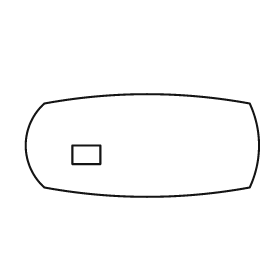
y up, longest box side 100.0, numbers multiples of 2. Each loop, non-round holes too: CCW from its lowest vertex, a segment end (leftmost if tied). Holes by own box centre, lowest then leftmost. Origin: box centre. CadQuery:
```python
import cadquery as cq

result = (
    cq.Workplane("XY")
    .moveTo(-42.0, -18.0)
    .threePointArc((2.0, -22.0), (46.0, -18.0))
    .threePointArc((50.0, 0.0), (46.0, 18.0))
    .threePointArc((2.0, 22.0), (-42.0, 18.0))
    .threePointArc((-50.0, 0.0), (-42.0, -18.0))
    .close()
    .moveTo(-30.0, -8.0)
    .lineTo(-18.0, -8.0)
    .lineTo(-18.0, 0.0)
    .lineTo(-30.0, 0.0)
    .close()
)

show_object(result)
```